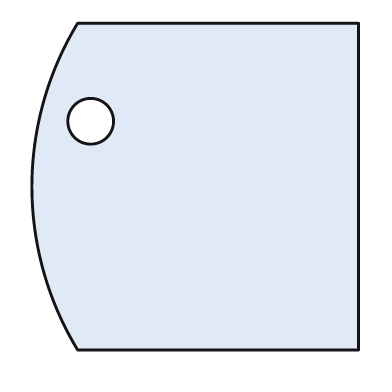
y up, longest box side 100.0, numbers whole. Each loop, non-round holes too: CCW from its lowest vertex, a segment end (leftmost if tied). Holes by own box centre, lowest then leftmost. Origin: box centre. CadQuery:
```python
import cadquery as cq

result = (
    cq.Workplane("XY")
    .moveTo(-36.0, -50.0)
    .lineTo(50.0, -50.0)
    .lineTo(50.0, 50.0)
    .lineTo(-36.0, 50.0)
    .threePointArc((-50.0, 0.0), (-36.0, -50.0))
    .close()
    .moveTo(-32.0, 20.0)
    .circle(7.0)
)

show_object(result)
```